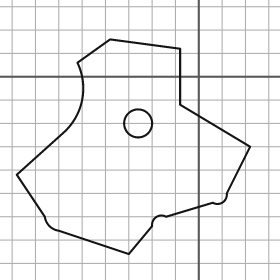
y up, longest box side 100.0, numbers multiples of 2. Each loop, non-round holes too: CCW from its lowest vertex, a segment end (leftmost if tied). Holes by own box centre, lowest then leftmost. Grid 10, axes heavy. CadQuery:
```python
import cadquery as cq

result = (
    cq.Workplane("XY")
    .moveTo(-30.0, -76.0)
    .lineTo(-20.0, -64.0)
    .threePointArc((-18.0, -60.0), (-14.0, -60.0))
    .lineTo(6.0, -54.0)
    .threePointArc((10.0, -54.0), (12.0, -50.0))
    .lineTo(22.0, -30.0)
    .lineTo(-8.0, -12.0)
    .lineTo(-8.0, 12.0)
    .lineTo(-38.0, 16.0)
    .lineTo(-52.0, 6.0)
    .threePointArc((-50.0, -10.0), (-58.0, -24.0))
    .lineTo(-78.0, -42.0)
    .lineTo(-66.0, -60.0)
    .threePointArc((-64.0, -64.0), (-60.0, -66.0))
    .close()
    .moveTo(-26.0, -20.0)
    .circle(6.0)
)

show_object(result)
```